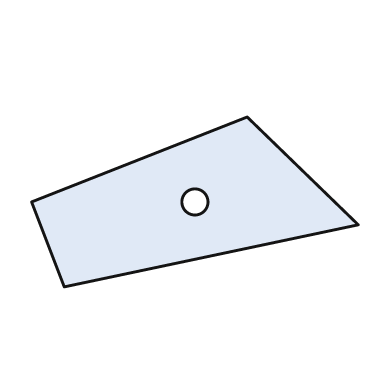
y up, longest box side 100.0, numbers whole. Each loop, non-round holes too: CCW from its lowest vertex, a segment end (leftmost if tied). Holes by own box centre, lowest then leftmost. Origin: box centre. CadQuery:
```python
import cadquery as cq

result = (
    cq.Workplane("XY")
    .moveTo(-40.0, -26.0)
    .lineTo(50.0, -7.0)
    .lineTo(16.0, 26.0)
    .lineTo(-50.0, 0.0)
    .close()
    .moveTo(0.0, 0.0)
    .circle(4.0)
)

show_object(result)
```